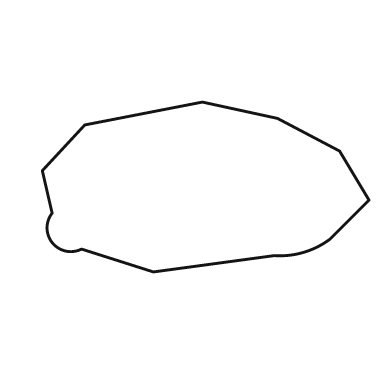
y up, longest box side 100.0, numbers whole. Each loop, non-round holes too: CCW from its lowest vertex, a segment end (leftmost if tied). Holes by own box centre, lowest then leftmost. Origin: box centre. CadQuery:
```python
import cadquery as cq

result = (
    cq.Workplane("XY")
    .moveTo(-16.0, -26.0)
    .lineTo(21.0, -21.0)
    .threePointArc((30.0, -20.0), (38.0, -16.0))
    .lineTo(50.0, -4.0)
    .lineTo(41.0, 11.0)
    .lineTo(22.0, 21.0)
    .lineTo(-1.0, 26.0)
    .lineTo(-37.0, 19.0)
    .lineTo(-50.0, 5.0)
    .lineTo(-47.0, -8.0)
    .threePointArc((-47.0, -17.0), (-38.0, -19.0))
    .close()
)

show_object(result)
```